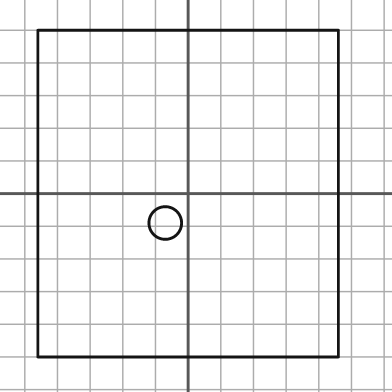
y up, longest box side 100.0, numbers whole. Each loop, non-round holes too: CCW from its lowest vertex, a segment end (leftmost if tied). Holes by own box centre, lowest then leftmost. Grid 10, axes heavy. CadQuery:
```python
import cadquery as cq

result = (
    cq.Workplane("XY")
    .moveTo(-46.0, -50.0)
    .lineTo(46.0, -50.0)
    .lineTo(46.0, 50.0)
    .lineTo(-46.0, 50.0)
    .close()
    .moveTo(-7.0, -9.0)
    .circle(5.0)
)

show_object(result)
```